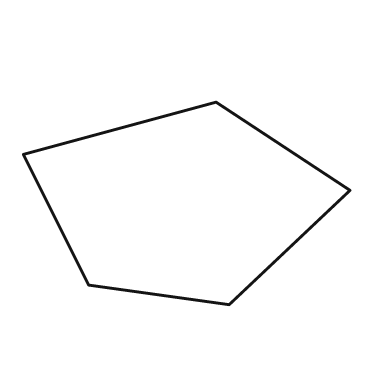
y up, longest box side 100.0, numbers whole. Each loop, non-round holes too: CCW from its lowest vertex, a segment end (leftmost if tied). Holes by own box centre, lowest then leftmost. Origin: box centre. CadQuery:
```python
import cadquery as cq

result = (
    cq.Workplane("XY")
    .moveTo(13.0, -31.0)
    .lineTo(50.0, 4.0)
    .lineTo(9.0, 31.0)
    .lineTo(-50.0, 15.0)
    .lineTo(-30.0, -25.0)
    .close()
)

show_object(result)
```